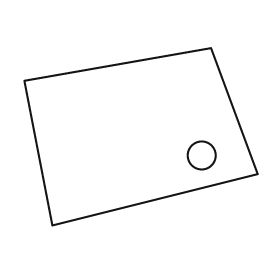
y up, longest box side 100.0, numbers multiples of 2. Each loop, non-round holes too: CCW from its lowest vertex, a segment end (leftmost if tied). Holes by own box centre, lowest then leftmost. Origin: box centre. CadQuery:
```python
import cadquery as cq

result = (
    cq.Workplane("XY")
    .moveTo(-38.0, -38.0)
    .lineTo(50.0, -16.0)
    .lineTo(30.0, 38.0)
    .lineTo(-50.0, 24.0)
    .close()
    .moveTo(26.0, -8.0)
    .circle(6.0)
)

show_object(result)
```